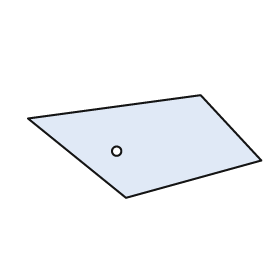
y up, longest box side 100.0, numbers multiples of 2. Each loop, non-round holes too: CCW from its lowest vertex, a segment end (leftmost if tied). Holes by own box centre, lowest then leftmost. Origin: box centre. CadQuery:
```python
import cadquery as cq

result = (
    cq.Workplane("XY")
    .moveTo(-8.0, -22.0)
    .lineTo(50.0, -6.0)
    .lineTo(24.0, 22.0)
    .lineTo(-50.0, 12.0)
    .close()
    .moveTo(-12.0, -2.0)
    .circle(2.0)
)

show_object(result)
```